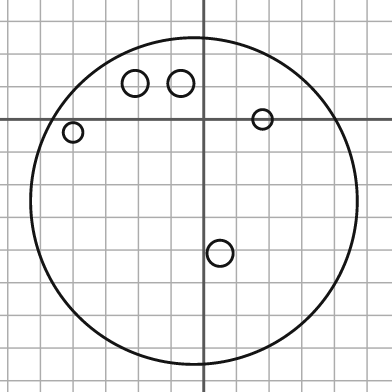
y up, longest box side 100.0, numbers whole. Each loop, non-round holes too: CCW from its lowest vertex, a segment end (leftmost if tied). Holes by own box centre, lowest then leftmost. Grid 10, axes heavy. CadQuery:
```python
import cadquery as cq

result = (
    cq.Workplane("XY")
    .moveTo(-3.0, -25.0)
    .circle(50.0)
    .moveTo(5.0, -41.0)
    .circle(4.0)
    .moveTo(-40.0, -4.0)
    .circle(3.0)
    .moveTo(18.0, 0.0)
    .circle(3.0)
    .moveTo(-21.0, 11.0)
    .circle(4.0)
    .moveTo(-7.0, 11.0)
    .circle(4.0)
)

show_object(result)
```